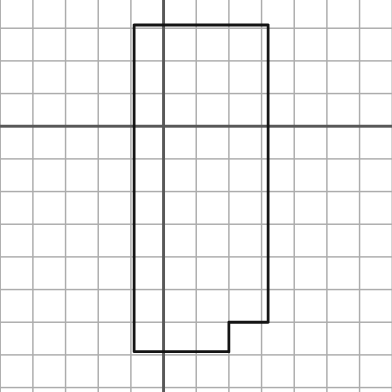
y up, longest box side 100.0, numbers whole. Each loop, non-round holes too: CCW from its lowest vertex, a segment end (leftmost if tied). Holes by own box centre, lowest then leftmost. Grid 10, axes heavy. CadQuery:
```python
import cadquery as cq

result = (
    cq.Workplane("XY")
    .moveTo(-9.0, -69.0)
    .lineTo(20.0, -69.0)
    .lineTo(20.0, -60.0)
    .lineTo(32.0, -60.0)
    .lineTo(32.0, 31.0)
    .lineTo(-9.0, 31.0)
    .close()
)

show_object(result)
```